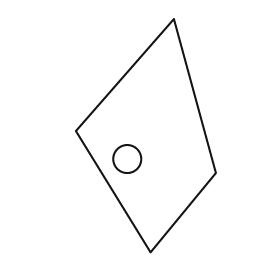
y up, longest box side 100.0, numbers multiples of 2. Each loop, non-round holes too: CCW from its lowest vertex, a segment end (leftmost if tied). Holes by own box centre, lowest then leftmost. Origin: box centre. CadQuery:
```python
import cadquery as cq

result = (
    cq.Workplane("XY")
    .moveTo(2.0, -50.0)
    .lineTo(30.0, -16.0)
    .lineTo(12.0, 50.0)
    .lineTo(-30.0, 2.0)
    .close()
    .moveTo(-8.0, -10.0)
    .circle(6.0)
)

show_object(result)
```